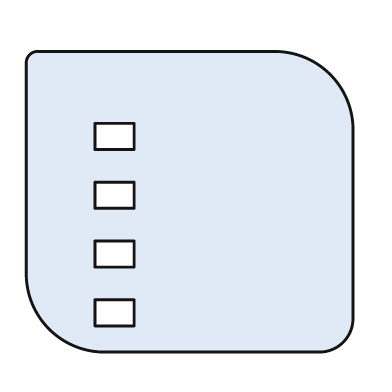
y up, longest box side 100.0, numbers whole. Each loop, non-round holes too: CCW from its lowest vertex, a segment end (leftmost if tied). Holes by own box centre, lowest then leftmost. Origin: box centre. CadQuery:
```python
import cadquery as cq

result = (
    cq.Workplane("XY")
    .moveTo(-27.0, -46.0)
    .lineTo(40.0, -46.0)
    .threePointArc((47.0, -43.0), (50.0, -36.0))
    .lineTo(50.0, 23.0)
    .threePointArc((43.0, 39.0), (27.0, 46.0))
    .lineTo(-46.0, 46.0)
    .threePointArc((-49.0, 45.0), (-50.0, 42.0))
    .lineTo(-50.0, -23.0)
    .threePointArc((-43.0, -39.0), (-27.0, -46.0))
    .close()
    .moveTo(-29.0, -38.0)
    .lineTo(-17.0, -38.0)
    .lineTo(-17.0, -30.0)
    .lineTo(-29.0, -30.0)
    .close()
    .moveTo(-29.0, -20.0)
    .lineTo(-17.0, -20.0)
    .lineTo(-17.0, -12.0)
    .lineTo(-29.0, -12.0)
    .close()
    .moveTo(-29.0, -2.0)
    .lineTo(-17.0, -2.0)
    .lineTo(-17.0, 6.0)
    .lineTo(-29.0, 6.0)
    .close()
    .moveTo(-29.0, 16.0)
    .lineTo(-17.0, 16.0)
    .lineTo(-17.0, 24.0)
    .lineTo(-29.0, 24.0)
    .close()
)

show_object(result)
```